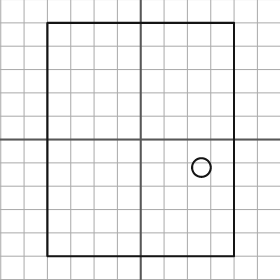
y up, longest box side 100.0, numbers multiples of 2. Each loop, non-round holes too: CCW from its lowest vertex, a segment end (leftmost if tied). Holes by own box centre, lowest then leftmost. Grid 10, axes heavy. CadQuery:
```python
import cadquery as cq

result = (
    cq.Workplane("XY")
    .moveTo(-40.0, -50.0)
    .lineTo(40.0, -50.0)
    .lineTo(40.0, 50.0)
    .lineTo(-40.0, 50.0)
    .close()
    .moveTo(26.0, -12.0)
    .circle(4.0)
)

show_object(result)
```